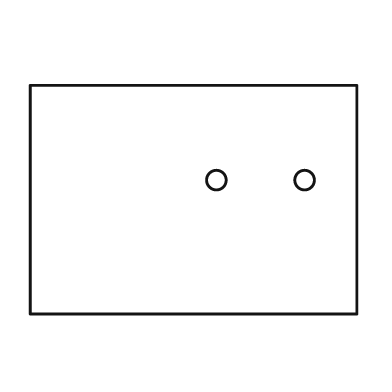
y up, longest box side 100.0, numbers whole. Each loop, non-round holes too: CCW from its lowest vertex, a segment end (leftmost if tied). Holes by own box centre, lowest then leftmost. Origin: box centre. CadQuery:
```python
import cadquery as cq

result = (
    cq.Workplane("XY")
    .moveTo(-50.0, -35.0)
    .lineTo(50.0, -35.0)
    .lineTo(50.0, 35.0)
    .lineTo(-50.0, 35.0)
    .close()
    .moveTo(7.0, 6.0)
    .circle(3.0)
    .moveTo(34.0, 6.0)
    .circle(3.0)
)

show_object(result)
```